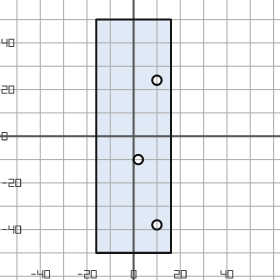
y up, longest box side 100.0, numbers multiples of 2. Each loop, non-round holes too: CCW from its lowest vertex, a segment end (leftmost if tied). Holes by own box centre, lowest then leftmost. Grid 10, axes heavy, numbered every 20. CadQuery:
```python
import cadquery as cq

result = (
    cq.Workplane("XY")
    .moveTo(-16.0, -50.0)
    .lineTo(16.0, -50.0)
    .lineTo(16.0, 50.0)
    .lineTo(-16.0, 50.0)
    .close()
    .moveTo(10.0, -38.0)
    .circle(2.0)
    .moveTo(2.0, -10.0)
    .circle(2.0)
    .moveTo(10.0, 24.0)
    .circle(2.0)
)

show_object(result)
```